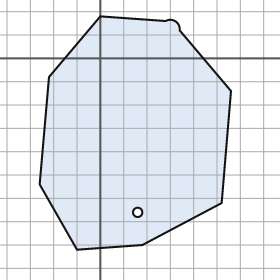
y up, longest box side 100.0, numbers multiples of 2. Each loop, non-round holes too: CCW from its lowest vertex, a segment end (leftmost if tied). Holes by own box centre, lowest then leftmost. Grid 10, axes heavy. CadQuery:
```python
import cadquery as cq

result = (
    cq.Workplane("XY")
    .moveTo(-10.0, -82.0)
    .lineTo(18.0, -80.0)
    .lineTo(52.0, -62.0)
    .lineTo(56.0, -14.0)
    .lineTo(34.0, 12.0)
    .threePointArc((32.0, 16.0), (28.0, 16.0))
    .lineTo(0.0, 18.0)
    .lineTo(-22.0, -8.0)
    .lineTo(-26.0, -54.0)
    .close()
    .moveTo(16.0, -66.0)
    .circle(2.0)
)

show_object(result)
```